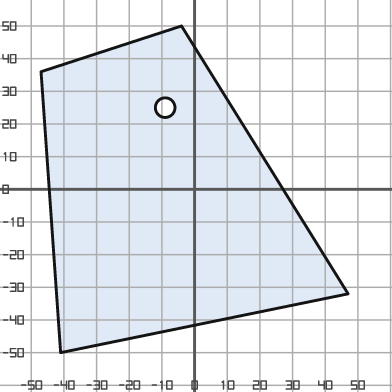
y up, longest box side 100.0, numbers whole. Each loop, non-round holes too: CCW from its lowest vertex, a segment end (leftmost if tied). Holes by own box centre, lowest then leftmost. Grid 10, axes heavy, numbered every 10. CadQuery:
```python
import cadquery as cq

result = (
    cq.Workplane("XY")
    .moveTo(-41.0, -50.0)
    .lineTo(47.0, -32.0)
    .lineTo(-4.0, 50.0)
    .lineTo(-47.0, 36.0)
    .close()
    .moveTo(-9.0, 25.0)
    .circle(3.0)
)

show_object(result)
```